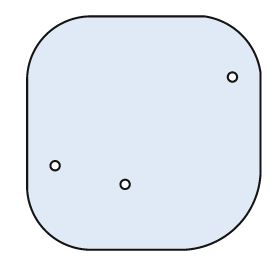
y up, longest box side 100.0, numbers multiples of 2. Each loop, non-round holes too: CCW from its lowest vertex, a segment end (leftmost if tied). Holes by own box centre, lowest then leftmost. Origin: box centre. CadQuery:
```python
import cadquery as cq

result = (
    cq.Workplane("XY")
    .moveTo(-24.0, -50.0)
    .lineTo(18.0, -50.0)
    .threePointArc((40.0, -40.0), (50.0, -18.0))
    .lineTo(50.0, 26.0)
    .threePointArc((42.0, 42.0), (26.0, 50.0))
    .lineTo(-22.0, 50.0)
    .threePointArc((-42.0, 42.0), (-50.0, 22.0))
    .lineTo(-50.0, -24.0)
    .threePointArc((-42.0, -42.0), (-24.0, -50.0))
    .close()
    .moveTo(-8.0, -22.0)
    .circle(2.0)
    .moveTo(-38.0, -14.0)
    .circle(2.0)
    .moveTo(38.0, 24.0)
    .circle(2.0)
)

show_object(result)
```